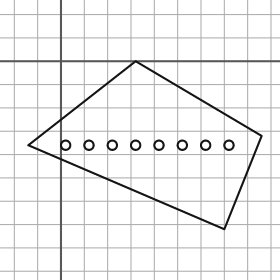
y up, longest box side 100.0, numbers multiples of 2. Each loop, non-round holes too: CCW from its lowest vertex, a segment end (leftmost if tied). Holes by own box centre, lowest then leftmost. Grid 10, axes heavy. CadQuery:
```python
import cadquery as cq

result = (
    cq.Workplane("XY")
    .moveTo(70.0, -72.0)
    .lineTo(86.0, -32.0)
    .lineTo(32.0, 0.0)
    .lineTo(-14.0, -36.0)
    .close()
    .moveTo(2.0, -36.0)
    .circle(2.0)
    .moveTo(12.0, -36.0)
    .circle(2.0)
    .moveTo(22.0, -36.0)
    .circle(2.0)
    .moveTo(32.0, -36.0)
    .circle(2.0)
    .moveTo(42.0, -36.0)
    .circle(2.0)
    .moveTo(52.0, -36.0)
    .circle(2.0)
    .moveTo(62.0, -36.0)
    .circle(2.0)
    .moveTo(72.0, -36.0)
    .circle(2.0)
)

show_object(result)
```